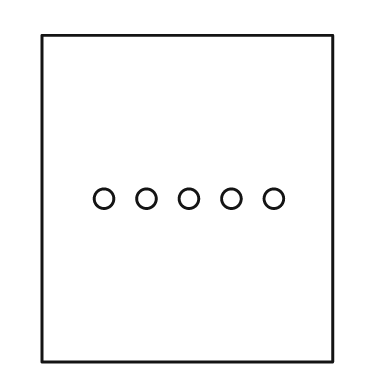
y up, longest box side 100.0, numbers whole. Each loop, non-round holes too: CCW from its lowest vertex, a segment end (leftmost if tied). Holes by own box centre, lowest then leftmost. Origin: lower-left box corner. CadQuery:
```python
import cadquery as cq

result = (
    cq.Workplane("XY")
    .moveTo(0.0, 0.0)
    .lineTo(89.0, 0.0)
    .lineTo(89.0, 100.0)
    .lineTo(0.0, 100.0)
    .close()
    .moveTo(19.0, 50.0)
    .circle(3.0)
    .moveTo(32.0, 50.0)
    .circle(3.0)
    .moveTo(45.0, 50.0)
    .circle(3.0)
    .moveTo(58.0, 50.0)
    .circle(3.0)
    .moveTo(71.0, 50.0)
    .circle(3.0)
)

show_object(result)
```